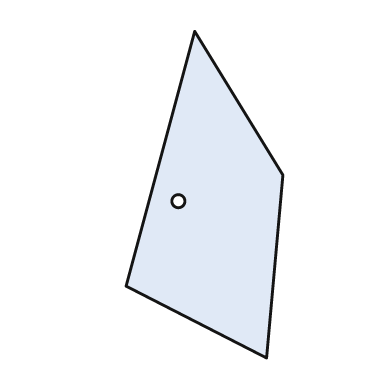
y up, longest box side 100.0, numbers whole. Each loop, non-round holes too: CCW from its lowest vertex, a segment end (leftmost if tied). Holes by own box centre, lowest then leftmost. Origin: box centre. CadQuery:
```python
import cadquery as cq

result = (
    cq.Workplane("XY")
    .moveTo(19.0, -50.0)
    .lineTo(24.0, 6.0)
    .lineTo(-3.0, 50.0)
    .lineTo(-24.0, -28.0)
    .close()
    .moveTo(-8.0, -2.0)
    .circle(2.0)
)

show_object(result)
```